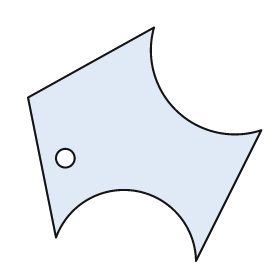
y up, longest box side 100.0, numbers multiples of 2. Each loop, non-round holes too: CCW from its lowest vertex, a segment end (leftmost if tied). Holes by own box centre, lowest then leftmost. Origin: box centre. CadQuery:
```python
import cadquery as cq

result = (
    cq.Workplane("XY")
    .moveTo(22.0, -50.0)
    .lineTo(50.0, 6.0)
    .threePointArc((14.0, 14.0), (4.0, 50.0))
    .lineTo(-50.0, 20.0)
    .lineTo(-38.0, -40.0)
    .threePointArc((-4.0, -20.0), (22.0, -50.0))
    .close()
    .moveTo(-34.0, -6.0)
    .circle(4.0)
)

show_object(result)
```